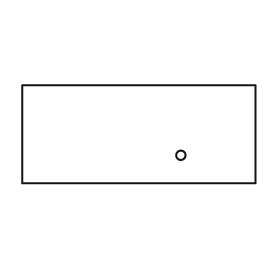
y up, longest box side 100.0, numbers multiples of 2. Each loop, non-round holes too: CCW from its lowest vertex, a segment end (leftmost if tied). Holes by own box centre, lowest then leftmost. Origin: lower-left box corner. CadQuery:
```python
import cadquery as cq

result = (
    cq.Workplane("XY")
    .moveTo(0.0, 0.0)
    .lineTo(100.0, 0.0)
    .lineTo(100.0, 42.0)
    .lineTo(0.0, 42.0)
    .close()
    .moveTo(68.0, 12.0)
    .circle(2.0)
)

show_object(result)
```